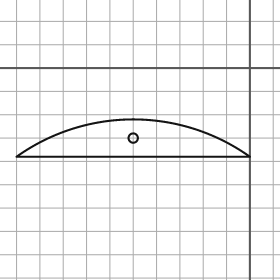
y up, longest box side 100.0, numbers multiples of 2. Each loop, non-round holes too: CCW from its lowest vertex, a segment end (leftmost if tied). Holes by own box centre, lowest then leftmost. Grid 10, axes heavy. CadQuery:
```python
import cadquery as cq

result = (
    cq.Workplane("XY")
    .moveTo(-100.0, -38.0)
    .lineTo(0.0, -38.0)
    .threePointArc((-50.0, -22.0), (-100.0, -38.0))
    .close()
    .moveTo(-50.0, -30.0)
    .circle(2.0)
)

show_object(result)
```